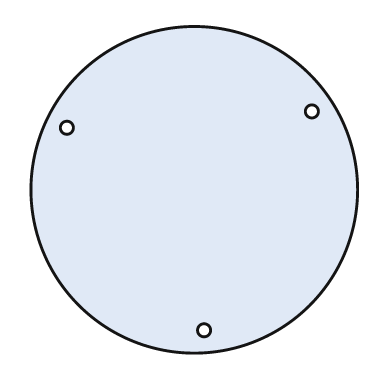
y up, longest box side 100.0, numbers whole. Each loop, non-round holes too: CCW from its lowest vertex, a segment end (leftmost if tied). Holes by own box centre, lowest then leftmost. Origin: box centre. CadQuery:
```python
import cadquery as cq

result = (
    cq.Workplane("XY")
    .moveTo(0.0, 0.0)
    .circle(50.0)
    .moveTo(3.0, -43.0)
    .circle(2.0)
    .moveTo(-39.0, 19.0)
    .circle(2.0)
    .moveTo(36.0, 24.0)
    .circle(2.0)
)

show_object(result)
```